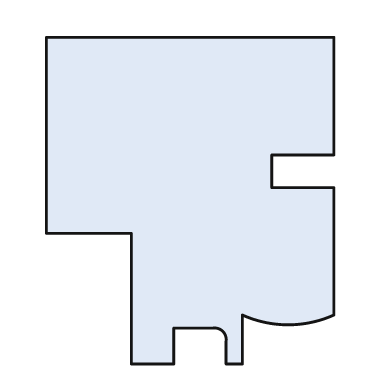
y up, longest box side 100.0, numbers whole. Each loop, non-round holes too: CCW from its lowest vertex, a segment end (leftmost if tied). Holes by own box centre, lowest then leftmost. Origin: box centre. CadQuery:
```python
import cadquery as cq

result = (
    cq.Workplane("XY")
    .moveTo(-18.0, -50.0)
    .lineTo(-5.0, -50.0)
    .lineTo(-5.0, -39.0)
    .lineTo(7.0, -39.0)
    .threePointArc((10.0, -40.0), (11.0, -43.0))
    .lineTo(11.0, -50.0)
    .lineTo(16.0, -50.0)
    .lineTo(16.0, -35.0)
    .threePointArc((30.0, -38.0), (44.0, -35.0))
    .lineTo(44.0, 4.0)
    .lineTo(25.0, 4.0)
    .lineTo(25.0, 14.0)
    .lineTo(44.0, 14.0)
    .lineTo(44.0, 50.0)
    .lineTo(-44.0, 50.0)
    .lineTo(-44.0, -10.0)
    .lineTo(-18.0, -10.0)
    .close()
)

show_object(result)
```